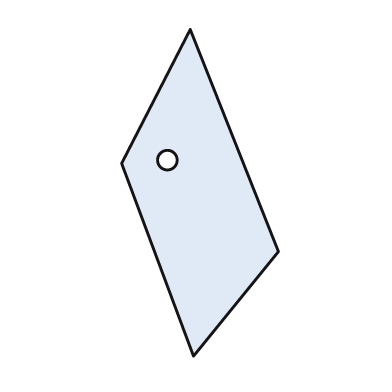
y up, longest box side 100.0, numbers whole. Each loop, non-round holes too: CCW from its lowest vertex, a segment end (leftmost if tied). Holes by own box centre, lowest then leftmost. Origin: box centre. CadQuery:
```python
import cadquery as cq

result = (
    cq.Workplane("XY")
    .moveTo(-2.0, -50.0)
    .lineTo(24.0, -18.0)
    .lineTo(-3.0, 50.0)
    .lineTo(-24.0, 9.0)
    .close()
    .moveTo(-10.0, 10.0)
    .circle(3.0)
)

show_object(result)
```